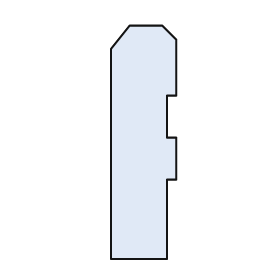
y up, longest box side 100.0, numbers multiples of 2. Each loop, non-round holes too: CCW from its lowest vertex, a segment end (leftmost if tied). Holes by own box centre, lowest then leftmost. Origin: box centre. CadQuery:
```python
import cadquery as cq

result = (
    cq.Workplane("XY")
    .moveTo(-14.0, -50.0)
    .lineTo(10.0, -50.0)
    .lineTo(10.0, -16.0)
    .lineTo(14.0, -16.0)
    .lineTo(14.0, 2.0)
    .lineTo(10.0, 2.0)
    .lineTo(10.0, 20.0)
    .lineTo(14.0, 20.0)
    .lineTo(14.0, 44.0)
    .lineTo(8.0, 50.0)
    .lineTo(-6.0, 50.0)
    .lineTo(-14.0, 40.0)
    .close()
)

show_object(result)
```